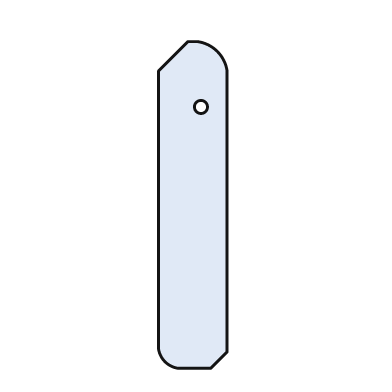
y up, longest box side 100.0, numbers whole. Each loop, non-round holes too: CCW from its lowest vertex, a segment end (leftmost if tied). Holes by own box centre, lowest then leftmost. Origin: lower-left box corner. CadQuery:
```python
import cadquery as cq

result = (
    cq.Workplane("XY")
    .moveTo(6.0, 0.0)
    .lineTo(16.0, 0.0)
    .lineTo(21.0, 5.0)
    .lineTo(21.0, 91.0)
    .threePointArc((18.0, 97.0), (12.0, 100.0))
    .lineTo(9.0, 100.0)
    .lineTo(0.0, 91.0)
    .lineTo(0.0, 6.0)
    .threePointArc((2.0, 2.0), (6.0, 0.0))
    .close()
    .moveTo(13.0, 80.0)
    .circle(2.0)
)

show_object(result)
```